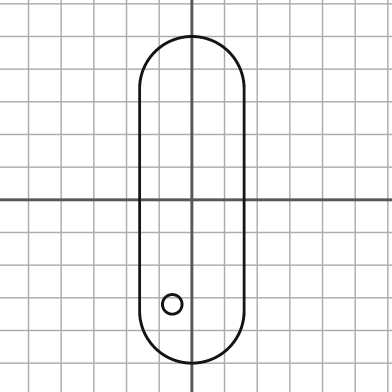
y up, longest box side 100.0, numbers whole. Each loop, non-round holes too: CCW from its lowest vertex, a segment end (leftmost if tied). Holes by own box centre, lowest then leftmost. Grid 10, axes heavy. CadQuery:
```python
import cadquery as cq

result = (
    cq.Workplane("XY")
    .moveTo(-16.0, -34.0)
    .threePointArc((0.0, -50.0), (16.0, -34.0))
    .lineTo(16.0, 34.0)
    .threePointArc((0.0, 50.0), (-16.0, 34.0))
    .close()
    .moveTo(-6.0, -32.0)
    .circle(3.0)
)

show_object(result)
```